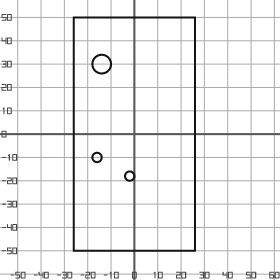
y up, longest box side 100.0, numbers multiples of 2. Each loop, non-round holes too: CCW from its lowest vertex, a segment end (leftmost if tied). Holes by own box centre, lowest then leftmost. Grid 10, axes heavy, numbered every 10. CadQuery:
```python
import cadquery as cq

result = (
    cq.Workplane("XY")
    .moveTo(-26.0, -50.0)
    .lineTo(26.0, -50.0)
    .lineTo(26.0, 50.0)
    .lineTo(-26.0, 50.0)
    .close()
    .moveTo(-2.0, -18.0)
    .circle(2.0)
    .moveTo(-16.0, -10.0)
    .circle(2.0)
    .moveTo(-14.0, 30.0)
    .circle(4.0)
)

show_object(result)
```